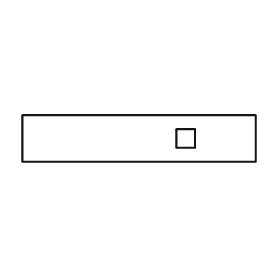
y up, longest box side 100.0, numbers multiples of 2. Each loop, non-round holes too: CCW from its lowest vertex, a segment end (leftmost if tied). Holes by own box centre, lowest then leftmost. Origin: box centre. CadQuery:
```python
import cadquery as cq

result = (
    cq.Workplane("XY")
    .moveTo(-50.0, -10.0)
    .lineTo(50.0, -10.0)
    .lineTo(50.0, 10.0)
    .lineTo(-50.0, 10.0)
    .close()
    .moveTo(16.0, -4.0)
    .lineTo(24.0, -4.0)
    .lineTo(24.0, 4.0)
    .lineTo(16.0, 4.0)
    .close()
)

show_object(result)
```